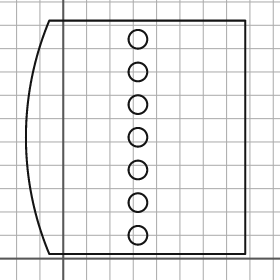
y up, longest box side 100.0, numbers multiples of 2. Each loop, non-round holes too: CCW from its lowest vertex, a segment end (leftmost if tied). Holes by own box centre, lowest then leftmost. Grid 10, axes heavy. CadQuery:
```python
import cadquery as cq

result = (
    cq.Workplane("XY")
    .moveTo(-6.0, 2.0)
    .lineTo(78.0, 2.0)
    .lineTo(78.0, 102.0)
    .lineTo(-6.0, 102.0)
    .threePointArc((-16.0, 52.0), (-6.0, 2.0))
    .close()
    .moveTo(32.0, 10.0)
    .circle(4.0)
    .moveTo(32.0, 24.0)
    .circle(4.0)
    .moveTo(32.0, 38.0)
    .circle(4.0)
    .moveTo(32.0, 52.0)
    .circle(4.0)
    .moveTo(32.0, 66.0)
    .circle(4.0)
    .moveTo(32.0, 80.0)
    .circle(4.0)
    .moveTo(32.0, 94.0)
    .circle(4.0)
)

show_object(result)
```